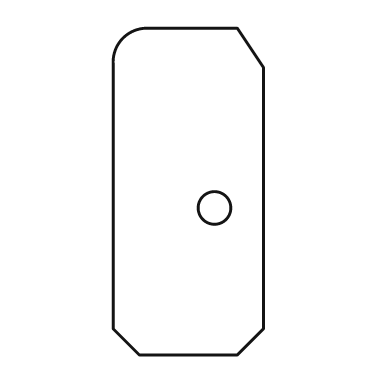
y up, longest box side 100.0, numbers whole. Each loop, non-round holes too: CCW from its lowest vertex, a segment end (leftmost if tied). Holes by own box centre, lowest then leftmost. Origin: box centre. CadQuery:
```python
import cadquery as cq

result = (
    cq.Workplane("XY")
    .moveTo(-15.0, -50.0)
    .lineTo(15.0, -50.0)
    .lineTo(23.0, -42.0)
    .lineTo(23.0, 38.0)
    .lineTo(15.0, 50.0)
    .lineTo(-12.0, 50.0)
    .threePointArc((-20.0, 47.0), (-23.0, 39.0))
    .lineTo(-23.0, -42.0)
    .close()
    .moveTo(8.0, -5.0)
    .circle(5.0)
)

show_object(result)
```